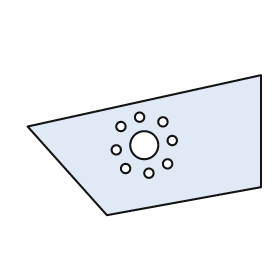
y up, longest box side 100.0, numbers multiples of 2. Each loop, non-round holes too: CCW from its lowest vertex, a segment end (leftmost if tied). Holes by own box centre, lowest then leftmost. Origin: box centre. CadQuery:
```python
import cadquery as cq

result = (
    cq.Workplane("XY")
    .moveTo(-16.0, -30.0)
    .lineTo(50.0, -18.0)
    .lineTo(50.0, 30.0)
    .lineTo(-50.0, 8.0)
    .close()
    .moveTo(2.0, -12.0)
    .circle(2.0)
    .moveTo(-8.0, -10.0)
    .circle(2.0)
    .moveTo(10.0, -8.0)
    .circle(2.0)
    .moveTo(-12.0, -2.0)
    .circle(2.0)
    .moveTo(0.0, 0.0)
    .circle(6.0)
    .moveTo(12.0, 2.0)
    .circle(2.0)
    .moveTo(-10.0, 8.0)
    .circle(2.0)
    .moveTo(8.0, 10.0)
    .circle(2.0)
    .moveTo(-2.0, 12.0)
    .circle(2.0)
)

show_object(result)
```